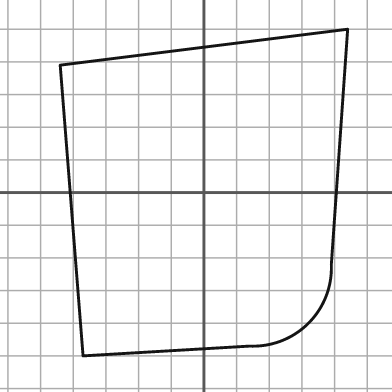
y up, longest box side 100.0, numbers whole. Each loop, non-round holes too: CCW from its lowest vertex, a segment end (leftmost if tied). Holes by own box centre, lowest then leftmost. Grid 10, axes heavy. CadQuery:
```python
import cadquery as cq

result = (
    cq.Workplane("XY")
    .moveTo(-37.0, -50.0)
    .lineTo(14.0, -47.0)
    .threePointArc((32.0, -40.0), (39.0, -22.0))
    .lineTo(44.0, 50.0)
    .lineTo(-44.0, 39.0)
    .close()
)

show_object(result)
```